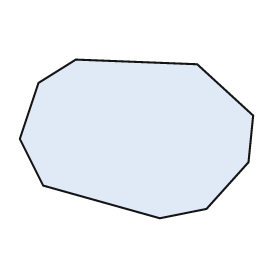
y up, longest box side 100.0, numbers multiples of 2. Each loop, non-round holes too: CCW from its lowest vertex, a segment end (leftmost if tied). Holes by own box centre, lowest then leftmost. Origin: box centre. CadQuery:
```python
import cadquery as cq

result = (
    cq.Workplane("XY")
    .moveTo(10.0, -34.0)
    .lineTo(30.0, -30.0)
    .lineTo(48.0, -10.0)
    .lineTo(50.0, 10.0)
    .lineTo(26.0, 32.0)
    .lineTo(-26.0, 34.0)
    .lineTo(-42.0, 24.0)
    .lineTo(-50.0, 0.0)
    .lineTo(-40.0, -20.0)
    .close()
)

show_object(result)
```